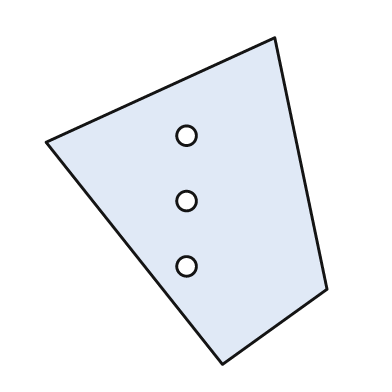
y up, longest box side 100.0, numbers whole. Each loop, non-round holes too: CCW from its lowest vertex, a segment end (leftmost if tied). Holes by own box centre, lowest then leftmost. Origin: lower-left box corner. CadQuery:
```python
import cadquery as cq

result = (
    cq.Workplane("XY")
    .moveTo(54.0, 0.0)
    .lineTo(86.0, 23.0)
    .lineTo(70.0, 100.0)
    .lineTo(0.0, 68.0)
    .close()
    .moveTo(43.0, 30.0)
    .circle(3.0)
    .moveTo(43.0, 50.0)
    .circle(3.0)
    .moveTo(43.0, 70.0)
    .circle(3.0)
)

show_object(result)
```